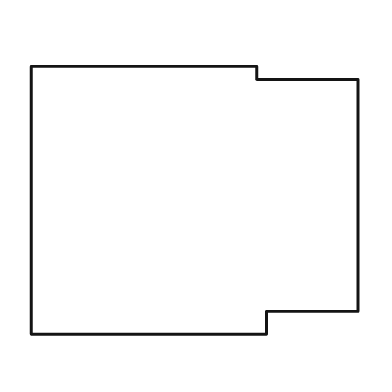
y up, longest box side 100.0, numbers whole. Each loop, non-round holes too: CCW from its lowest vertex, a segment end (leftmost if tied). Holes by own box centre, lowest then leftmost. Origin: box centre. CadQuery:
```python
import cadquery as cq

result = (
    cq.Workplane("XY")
    .moveTo(-50.0, -41.0)
    .lineTo(22.0, -41.0)
    .lineTo(22.0, -34.0)
    .lineTo(50.0, -34.0)
    .lineTo(50.0, 37.0)
    .lineTo(19.0, 37.0)
    .lineTo(19.0, 41.0)
    .lineTo(-50.0, 41.0)
    .close()
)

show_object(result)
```